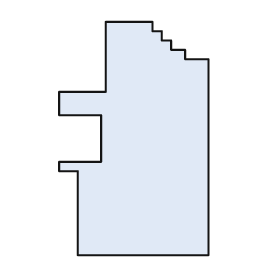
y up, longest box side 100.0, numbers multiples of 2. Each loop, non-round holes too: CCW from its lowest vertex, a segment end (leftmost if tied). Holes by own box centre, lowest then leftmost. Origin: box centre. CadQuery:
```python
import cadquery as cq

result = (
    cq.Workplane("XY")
    .moveTo(-24.0, -50.0)
    .lineTo(32.0, -50.0)
    .lineTo(32.0, 34.0)
    .lineTo(22.0, 34.0)
    .lineTo(22.0, 38.0)
    .lineTo(16.0, 38.0)
    .lineTo(16.0, 42.0)
    .lineTo(12.0, 42.0)
    .lineTo(12.0, 46.0)
    .lineTo(8.0, 46.0)
    .lineTo(8.0, 50.0)
    .lineTo(-12.0, 50.0)
    .lineTo(-12.0, 20.0)
    .lineTo(-32.0, 20.0)
    .lineTo(-32.0, 10.0)
    .lineTo(-14.0, 10.0)
    .lineTo(-14.0, -10.0)
    .lineTo(-32.0, -10.0)
    .lineTo(-32.0, -14.0)
    .lineTo(-24.0, -14.0)
    .close()
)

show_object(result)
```